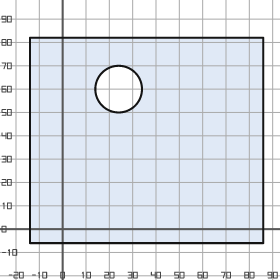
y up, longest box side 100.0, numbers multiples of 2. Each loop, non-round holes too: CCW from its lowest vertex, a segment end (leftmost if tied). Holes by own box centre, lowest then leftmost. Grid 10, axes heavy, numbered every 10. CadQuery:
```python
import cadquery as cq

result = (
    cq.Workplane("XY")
    .moveTo(-14.0, -6.0)
    .lineTo(86.0, -6.0)
    .lineTo(86.0, 82.0)
    .lineTo(-14.0, 82.0)
    .close()
    .moveTo(24.0, 60.0)
    .circle(10.0)
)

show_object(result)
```